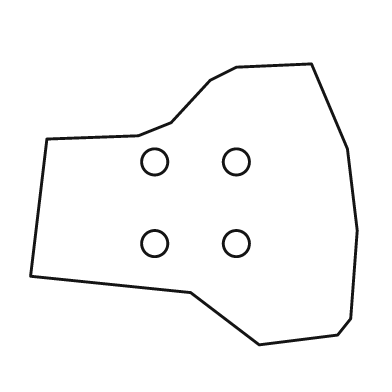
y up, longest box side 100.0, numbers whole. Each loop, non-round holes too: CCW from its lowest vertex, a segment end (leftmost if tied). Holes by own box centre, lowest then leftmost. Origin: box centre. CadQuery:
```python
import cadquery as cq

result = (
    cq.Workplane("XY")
    .moveTo(20.0, -43.0)
    .lineTo(44.0, -40.0)
    .lineTo(48.0, -35.0)
    .lineTo(50.0, -8.0)
    .lineTo(47.0, 17.0)
    .lineTo(36.0, 43.0)
    .lineTo(13.0, 42.0)
    .lineTo(5.0, 38.0)
    .lineTo(-7.0, 25.0)
    .lineTo(-17.0, 21.0)
    .lineTo(-45.0, 20.0)
    .lineTo(-50.0, -22.0)
    .lineTo(-1.0, -27.0)
    .close()
    .moveTo(-12.0, -12.0)
    .circle(4.0)
    .moveTo(13.0, -12.0)
    .circle(4.0)
    .moveTo(-12.0, 13.0)
    .circle(4.0)
    .moveTo(13.0, 13.0)
    .circle(4.0)
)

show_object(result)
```